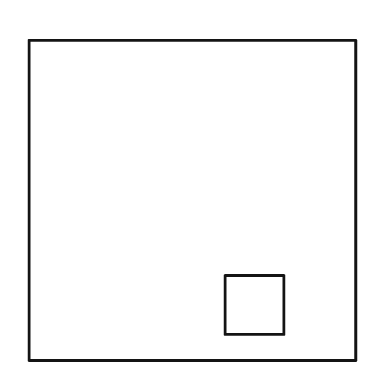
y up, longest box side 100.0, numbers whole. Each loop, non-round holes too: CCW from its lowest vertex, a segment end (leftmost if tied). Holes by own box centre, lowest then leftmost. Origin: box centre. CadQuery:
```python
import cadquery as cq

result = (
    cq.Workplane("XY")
    .moveTo(-50.0, -49.0)
    .lineTo(50.0, -49.0)
    .lineTo(50.0, 49.0)
    .lineTo(-50.0, 49.0)
    .close()
    .moveTo(10.0, -41.0)
    .lineTo(28.0, -41.0)
    .lineTo(28.0, -23.0)
    .lineTo(10.0, -23.0)
    .close()
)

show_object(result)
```